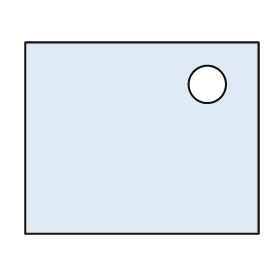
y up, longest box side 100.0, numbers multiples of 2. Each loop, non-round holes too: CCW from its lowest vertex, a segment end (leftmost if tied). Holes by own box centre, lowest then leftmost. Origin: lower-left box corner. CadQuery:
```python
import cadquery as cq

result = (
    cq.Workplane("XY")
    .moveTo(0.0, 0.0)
    .lineTo(100.0, 0.0)
    .lineTo(100.0, 82.0)
    .lineTo(0.0, 82.0)
    .close()
    .moveTo(78.0, 64.0)
    .circle(8.0)
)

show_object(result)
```